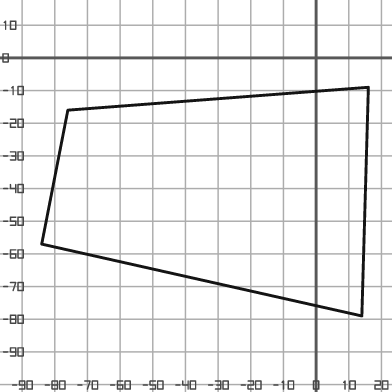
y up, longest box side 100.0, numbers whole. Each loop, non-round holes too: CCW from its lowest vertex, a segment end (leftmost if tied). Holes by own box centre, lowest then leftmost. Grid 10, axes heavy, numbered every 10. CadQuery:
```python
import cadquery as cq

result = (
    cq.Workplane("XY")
    .moveTo(14.0, -79.0)
    .lineTo(16.0, -9.0)
    .lineTo(-76.0, -16.0)
    .lineTo(-84.0, -57.0)
    .close()
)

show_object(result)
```